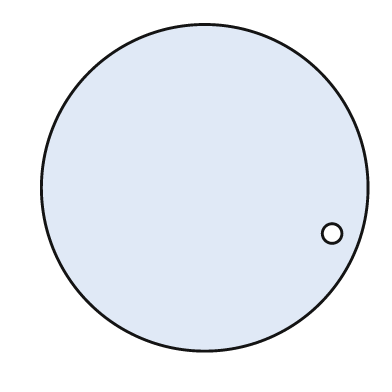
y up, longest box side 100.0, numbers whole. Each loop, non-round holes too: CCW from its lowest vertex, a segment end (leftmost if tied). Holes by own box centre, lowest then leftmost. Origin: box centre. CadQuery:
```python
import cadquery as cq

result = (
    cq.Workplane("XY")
    .moveTo(0.0, 0.0)
    .circle(50.0)
    .moveTo(39.0, -14.0)
    .circle(3.0)
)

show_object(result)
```